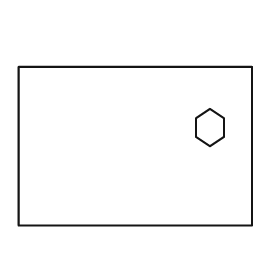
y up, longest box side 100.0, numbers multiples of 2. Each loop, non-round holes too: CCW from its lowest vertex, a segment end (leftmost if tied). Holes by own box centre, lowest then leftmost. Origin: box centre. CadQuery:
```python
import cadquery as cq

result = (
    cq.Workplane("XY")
    .moveTo(-50.0, -34.0)
    .lineTo(50.0, -34.0)
    .lineTo(50.0, 34.0)
    .lineTo(-50.0, 34.0)
    .close()
    .moveTo(32.0, 0.0)
    .lineTo(38.0, 4.0)
    .lineTo(38.0, 12.0)
    .lineTo(32.0, 16.0)
    .lineTo(26.0, 12.0)
    .lineTo(26.0, 4.0)
    .close()
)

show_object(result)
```